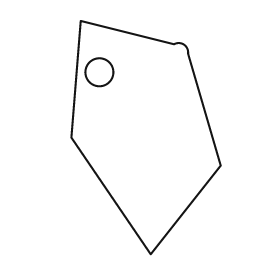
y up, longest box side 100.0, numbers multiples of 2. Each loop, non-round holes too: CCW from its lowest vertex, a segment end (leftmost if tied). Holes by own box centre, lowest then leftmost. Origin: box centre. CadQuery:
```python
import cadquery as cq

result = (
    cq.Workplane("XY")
    .moveTo(2.0, -50.0)
    .lineTo(32.0, -12.0)
    .lineTo(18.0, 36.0)
    .threePointArc((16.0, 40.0), (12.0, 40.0))
    .lineTo(-28.0, 50.0)
    .lineTo(-32.0, 0.0)
    .close()
    .moveTo(-20.0, 28.0)
    .circle(6.0)
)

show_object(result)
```